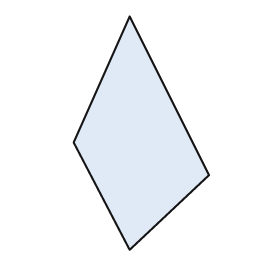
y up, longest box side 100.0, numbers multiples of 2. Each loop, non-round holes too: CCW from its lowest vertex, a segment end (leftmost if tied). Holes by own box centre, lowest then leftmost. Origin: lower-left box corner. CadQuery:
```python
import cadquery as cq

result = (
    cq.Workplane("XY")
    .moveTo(24.0, 0.0)
    .lineTo(58.0, 32.0)
    .lineTo(24.0, 100.0)
    .lineTo(0.0, 46.0)
    .close()
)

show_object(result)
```